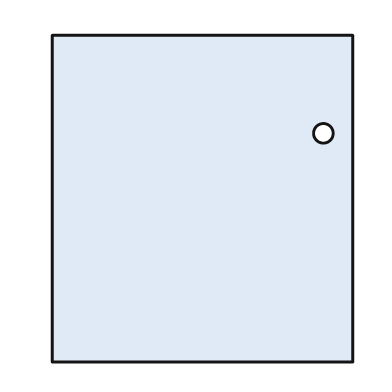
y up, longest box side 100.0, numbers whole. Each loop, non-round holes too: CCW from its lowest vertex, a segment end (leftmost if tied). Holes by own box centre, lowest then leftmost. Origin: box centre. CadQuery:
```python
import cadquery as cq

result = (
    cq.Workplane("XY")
    .moveTo(-46.0, -50.0)
    .lineTo(46.0, -50.0)
    .lineTo(46.0, 50.0)
    .lineTo(-46.0, 50.0)
    .close()
    .moveTo(37.0, 20.0)
    .circle(3.0)
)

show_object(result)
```